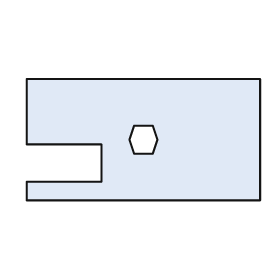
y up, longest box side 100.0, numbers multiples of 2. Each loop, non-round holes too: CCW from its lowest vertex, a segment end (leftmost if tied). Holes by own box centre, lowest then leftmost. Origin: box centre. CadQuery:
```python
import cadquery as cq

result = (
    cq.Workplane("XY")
    .moveTo(-50.0, -26.0)
    .lineTo(50.0, -26.0)
    .lineTo(50.0, 26.0)
    .lineTo(-50.0, 26.0)
    .lineTo(-50.0, -2.0)
    .lineTo(-18.0, -2.0)
    .lineTo(-18.0, -18.0)
    .lineTo(-50.0, -18.0)
    .close()
    .moveTo(-4.0, -6.0)
    .lineTo(4.0, -6.0)
    .lineTo(6.0, 0.0)
    .lineTo(4.0, 6.0)
    .lineTo(-4.0, 6.0)
    .lineTo(-6.0, 0.0)
    .close()
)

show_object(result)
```